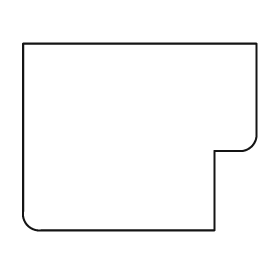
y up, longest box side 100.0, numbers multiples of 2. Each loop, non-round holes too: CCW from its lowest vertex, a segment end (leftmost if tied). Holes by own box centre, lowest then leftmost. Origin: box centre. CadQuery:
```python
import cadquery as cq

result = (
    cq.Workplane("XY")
    .moveTo(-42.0, -40.0)
    .lineTo(32.0, -40.0)
    .lineTo(32.0, -6.0)
    .lineTo(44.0, -6.0)
    .threePointArc((48.0, -4.0), (50.0, 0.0))
    .lineTo(50.0, 40.0)
    .lineTo(-50.0, 40.0)
    .lineTo(-50.0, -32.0)
    .threePointArc((-48.0, -38.0), (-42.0, -40.0))
    .close()
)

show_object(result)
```